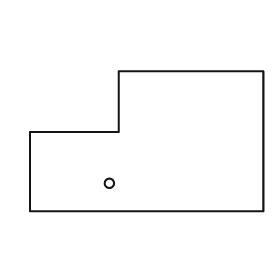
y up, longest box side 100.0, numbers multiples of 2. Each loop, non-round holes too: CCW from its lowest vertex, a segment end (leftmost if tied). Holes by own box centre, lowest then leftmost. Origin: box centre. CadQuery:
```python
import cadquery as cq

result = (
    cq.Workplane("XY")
    .moveTo(-50.0, -30.0)
    .lineTo(50.0, -30.0)
    .lineTo(50.0, 30.0)
    .lineTo(-12.0, 30.0)
    .lineTo(-12.0, 4.0)
    .lineTo(-50.0, 4.0)
    .close()
    .moveTo(-16.0, -18.0)
    .circle(2.0)
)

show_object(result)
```